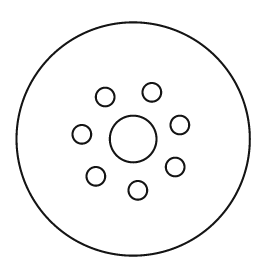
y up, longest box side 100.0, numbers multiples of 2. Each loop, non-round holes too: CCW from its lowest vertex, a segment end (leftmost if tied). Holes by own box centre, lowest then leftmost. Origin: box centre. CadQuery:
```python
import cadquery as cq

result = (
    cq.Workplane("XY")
    .moveTo(0.0, 0.0)
    .circle(50.0)
    .moveTo(2.0, -22.0)
    .circle(4.0)
    .moveTo(-16.0, -16.0)
    .circle(4.0)
    .moveTo(18.0, -12.0)
    .circle(4.0)
    .moveTo(0.0, 0.0)
    .circle(10.0)
    .moveTo(-22.0, 2.0)
    .circle(4.0)
    .moveTo(20.0, 6.0)
    .circle(4.0)
    .moveTo(-12.0, 18.0)
    .circle(4.0)
    .moveTo(8.0, 20.0)
    .circle(4.0)
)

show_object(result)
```